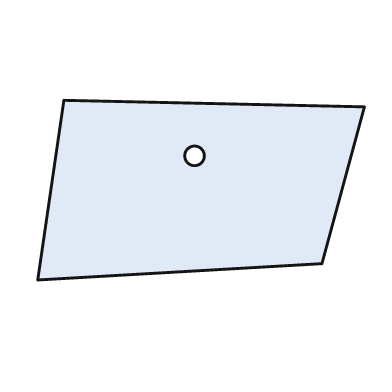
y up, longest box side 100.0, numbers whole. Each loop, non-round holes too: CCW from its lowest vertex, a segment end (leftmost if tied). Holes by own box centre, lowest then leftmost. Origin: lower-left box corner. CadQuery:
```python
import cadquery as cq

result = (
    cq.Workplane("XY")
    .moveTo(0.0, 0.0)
    .lineTo(87.0, 5.0)
    .lineTo(100.0, 53.0)
    .lineTo(8.0, 55.0)
    .close()
    .moveTo(48.0, 38.0)
    .circle(3.0)
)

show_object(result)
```